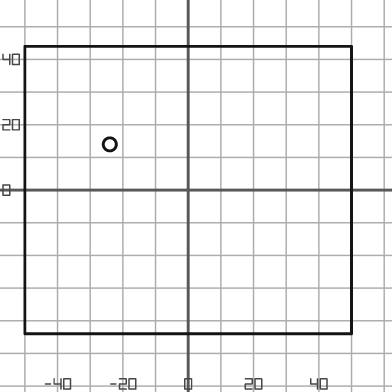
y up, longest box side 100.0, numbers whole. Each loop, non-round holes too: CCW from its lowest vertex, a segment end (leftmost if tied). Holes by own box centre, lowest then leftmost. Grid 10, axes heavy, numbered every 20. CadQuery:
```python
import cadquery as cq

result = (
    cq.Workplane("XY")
    .moveTo(-50.0, -44.0)
    .lineTo(50.0, -44.0)
    .lineTo(50.0, 44.0)
    .lineTo(-50.0, 44.0)
    .close()
    .moveTo(-24.0, 14.0)
    .circle(2.0)
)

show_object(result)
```